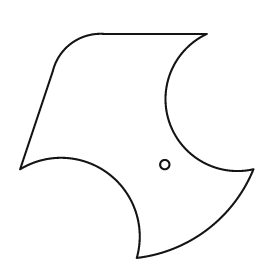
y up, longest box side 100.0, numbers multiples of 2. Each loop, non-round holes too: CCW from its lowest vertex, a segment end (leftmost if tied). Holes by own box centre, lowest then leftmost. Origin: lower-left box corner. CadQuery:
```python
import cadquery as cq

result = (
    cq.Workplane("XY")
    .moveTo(50.0, 0.0)
    .threePointArc((80.0, 12.0), (100.0, 38.0))
    .threePointArc((64.0, 58.0), (80.0, 96.0))
    .lineTo(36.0, 96.0)
    .threePointArc((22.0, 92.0), (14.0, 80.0))
    .lineTo(0.0, 38.0)
    .threePointArc((38.0, 36.0), (50.0, 0.0))
    .close()
    .moveTo(62.0, 40.0)
    .circle(2.0)
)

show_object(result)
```